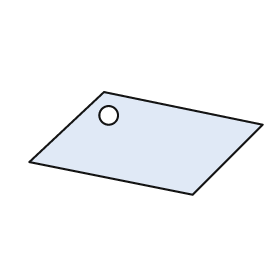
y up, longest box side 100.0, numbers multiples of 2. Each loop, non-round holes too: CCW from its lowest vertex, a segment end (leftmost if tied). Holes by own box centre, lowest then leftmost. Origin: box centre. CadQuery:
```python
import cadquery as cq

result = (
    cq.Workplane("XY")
    .moveTo(20.0, -22.0)
    .lineTo(50.0, 8.0)
    .lineTo(-18.0, 22.0)
    .lineTo(-50.0, -8.0)
    .close()
    .moveTo(-16.0, 12.0)
    .circle(4.0)
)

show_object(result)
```